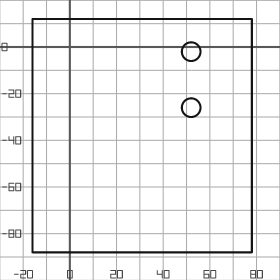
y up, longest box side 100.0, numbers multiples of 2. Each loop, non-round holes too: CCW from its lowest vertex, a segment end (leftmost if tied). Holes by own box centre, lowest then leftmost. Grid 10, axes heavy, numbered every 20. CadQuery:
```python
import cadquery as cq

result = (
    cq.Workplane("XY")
    .moveTo(-16.0, -88.0)
    .lineTo(78.0, -88.0)
    .lineTo(78.0, 12.0)
    .lineTo(-16.0, 12.0)
    .close()
    .moveTo(52.0, -26.0)
    .circle(4.0)
    .moveTo(52.0, -2.0)
    .circle(4.0)
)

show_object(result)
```